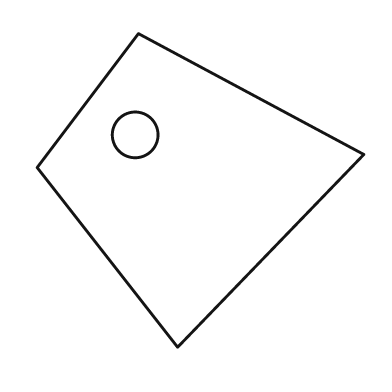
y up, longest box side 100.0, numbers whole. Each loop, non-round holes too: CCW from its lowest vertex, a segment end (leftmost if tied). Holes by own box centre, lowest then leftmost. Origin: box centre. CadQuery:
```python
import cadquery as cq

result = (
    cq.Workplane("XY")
    .moveTo(-7.0, -48.0)
    .lineTo(50.0, 11.0)
    .lineTo(-19.0, 48.0)
    .lineTo(-50.0, 7.0)
    .close()
    .moveTo(-20.0, 17.0)
    .circle(7.0)
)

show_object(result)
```